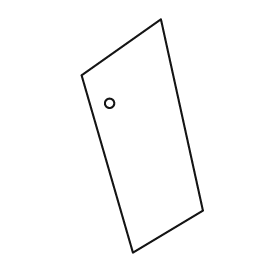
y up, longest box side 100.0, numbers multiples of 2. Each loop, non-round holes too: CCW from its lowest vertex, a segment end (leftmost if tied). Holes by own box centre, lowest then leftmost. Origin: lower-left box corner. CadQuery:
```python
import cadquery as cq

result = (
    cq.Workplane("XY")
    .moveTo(22.0, 0.0)
    .lineTo(52.0, 18.0)
    .lineTo(34.0, 100.0)
    .lineTo(0.0, 76.0)
    .close()
    .moveTo(12.0, 64.0)
    .circle(2.0)
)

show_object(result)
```